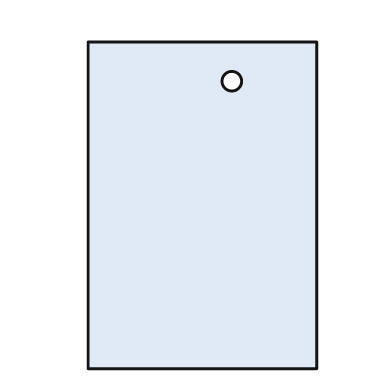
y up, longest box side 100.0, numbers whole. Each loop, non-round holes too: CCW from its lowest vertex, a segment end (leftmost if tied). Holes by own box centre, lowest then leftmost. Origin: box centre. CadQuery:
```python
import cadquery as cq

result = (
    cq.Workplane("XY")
    .moveTo(-35.0, -50.0)
    .lineTo(35.0, -50.0)
    .lineTo(35.0, 50.0)
    .lineTo(-35.0, 50.0)
    .close()
    .moveTo(9.0, 38.0)
    .circle(3.0)
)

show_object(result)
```